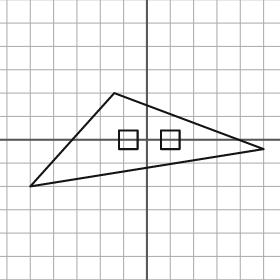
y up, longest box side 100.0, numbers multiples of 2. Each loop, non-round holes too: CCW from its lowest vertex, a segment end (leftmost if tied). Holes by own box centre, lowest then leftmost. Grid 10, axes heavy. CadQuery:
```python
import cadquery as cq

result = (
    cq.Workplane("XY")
    .moveTo(-50.0, -20.0)
    .lineTo(50.0, -4.0)
    .lineTo(-14.0, 20.0)
    .close()
    .moveTo(-12.0, -4.0)
    .lineTo(-4.0, -4.0)
    .lineTo(-4.0, 4.0)
    .lineTo(-12.0, 4.0)
    .close()
    .moveTo(6.0, -4.0)
    .lineTo(14.0, -4.0)
    .lineTo(14.0, 4.0)
    .lineTo(6.0, 4.0)
    .close()
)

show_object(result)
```